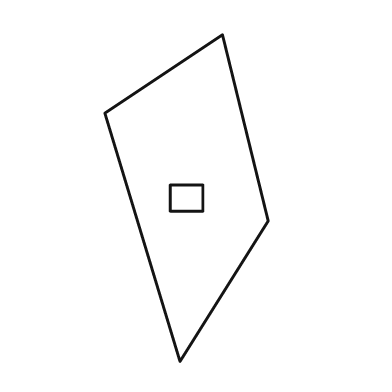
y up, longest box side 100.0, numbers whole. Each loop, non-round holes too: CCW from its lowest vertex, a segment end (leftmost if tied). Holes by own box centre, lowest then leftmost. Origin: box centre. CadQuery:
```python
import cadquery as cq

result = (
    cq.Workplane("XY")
    .moveTo(-2.0, -50.0)
    .lineTo(25.0, -7.0)
    .lineTo(11.0, 50.0)
    .lineTo(-25.0, 26.0)
    .close()
    .moveTo(-5.0, -4.0)
    .lineTo(5.0, -4.0)
    .lineTo(5.0, 4.0)
    .lineTo(-5.0, 4.0)
    .close()
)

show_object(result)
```